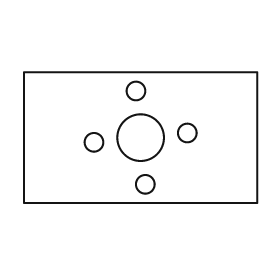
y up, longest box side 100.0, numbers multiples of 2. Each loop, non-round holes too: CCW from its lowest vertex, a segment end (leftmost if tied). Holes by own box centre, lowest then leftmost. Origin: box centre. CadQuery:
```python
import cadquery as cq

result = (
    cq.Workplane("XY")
    .moveTo(-50.0, -28.0)
    .lineTo(50.0, -28.0)
    .lineTo(50.0, 28.0)
    .lineTo(-50.0, 28.0)
    .close()
    .moveTo(2.0, -20.0)
    .circle(4.0)
    .moveTo(-20.0, -2.0)
    .circle(4.0)
    .moveTo(0.0, 0.0)
    .circle(10.0)
    .moveTo(20.0, 2.0)
    .circle(4.0)
    .moveTo(-2.0, 20.0)
    .circle(4.0)
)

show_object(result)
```